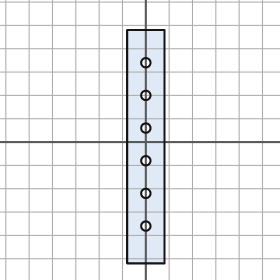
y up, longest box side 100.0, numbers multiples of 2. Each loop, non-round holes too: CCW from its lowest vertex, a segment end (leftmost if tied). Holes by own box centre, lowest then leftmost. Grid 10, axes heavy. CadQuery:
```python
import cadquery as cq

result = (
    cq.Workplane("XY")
    .moveTo(-8.0, -52.0)
    .lineTo(8.0, -52.0)
    .lineTo(8.0, 48.0)
    .lineTo(-8.0, 48.0)
    .close()
    .moveTo(0.0, -36.0)
    .circle(2.0)
    .moveTo(0.0, -22.0)
    .circle(2.0)
    .moveTo(0.0, -8.0)
    .circle(2.0)
    .moveTo(0.0, 6.0)
    .circle(2.0)
    .moveTo(0.0, 20.0)
    .circle(2.0)
    .moveTo(0.0, 34.0)
    .circle(2.0)
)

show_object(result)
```